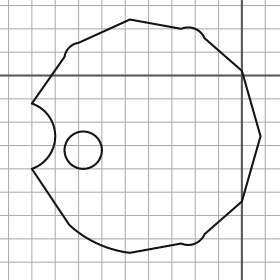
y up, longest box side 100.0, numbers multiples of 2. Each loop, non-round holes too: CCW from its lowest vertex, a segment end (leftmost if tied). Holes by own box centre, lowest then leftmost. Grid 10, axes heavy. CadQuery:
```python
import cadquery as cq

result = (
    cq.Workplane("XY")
    .moveTo(-48.0, -76.0)
    .lineTo(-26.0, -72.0)
    .threePointArc((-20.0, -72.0), (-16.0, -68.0))
    .lineTo(0.0, -54.0)
    .lineTo(8.0, -26.0)
    .lineTo(0.0, 2.0)
    .lineTo(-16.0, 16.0)
    .threePointArc((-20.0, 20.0), (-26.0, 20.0))
    .lineTo(-48.0, 24.0)
    .lineTo(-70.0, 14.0)
    .threePointArc((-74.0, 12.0), (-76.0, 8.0))
    .lineTo(-90.0, -12.0)
    .threePointArc((-80.0, -26.0), (-90.0, -40.0))
    .lineTo(-74.0, -64.0)
    .threePointArc((-62.0, -72.0), (-48.0, -76.0))
    .close()
    .moveTo(-68.0, -32.0)
    .circle(8.0)
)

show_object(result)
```